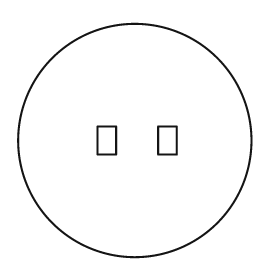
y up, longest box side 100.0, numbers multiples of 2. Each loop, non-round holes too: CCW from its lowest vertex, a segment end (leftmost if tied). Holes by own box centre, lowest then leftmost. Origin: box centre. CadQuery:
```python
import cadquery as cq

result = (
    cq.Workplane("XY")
    .moveTo(0.0, 0.0)
    .circle(50.0)
    .moveTo(-16.0, -6.0)
    .lineTo(-8.0, -6.0)
    .lineTo(-8.0, 6.0)
    .lineTo(-16.0, 6.0)
    .close()
    .moveTo(10.0, -6.0)
    .lineTo(18.0, -6.0)
    .lineTo(18.0, 6.0)
    .lineTo(10.0, 6.0)
    .close()
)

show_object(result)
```